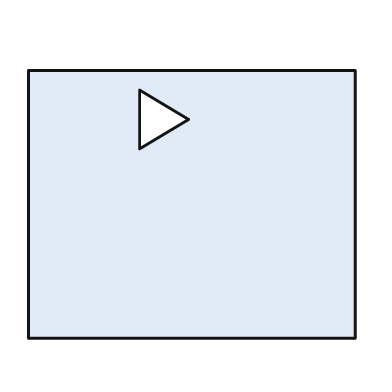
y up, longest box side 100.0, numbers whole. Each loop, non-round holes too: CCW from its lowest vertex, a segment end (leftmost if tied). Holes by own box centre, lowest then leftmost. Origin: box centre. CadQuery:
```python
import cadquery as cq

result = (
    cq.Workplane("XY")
    .moveTo(-50.0, -41.0)
    .lineTo(50.0, -41.0)
    .lineTo(50.0, 41.0)
    .lineTo(-50.0, 41.0)
    .close()
    .moveTo(-16.0, 17.0)
    .lineTo(-1.0, 26.0)
    .lineTo(-16.0, 35.0)
    .close()
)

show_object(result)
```